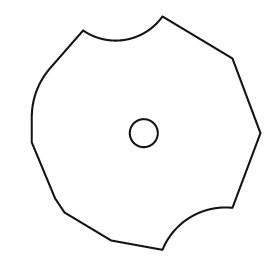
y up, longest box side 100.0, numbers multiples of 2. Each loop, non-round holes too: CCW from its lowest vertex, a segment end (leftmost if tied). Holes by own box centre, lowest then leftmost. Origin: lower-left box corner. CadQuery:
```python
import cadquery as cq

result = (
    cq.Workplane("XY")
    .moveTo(56.0, 0.0)
    .threePointArc((68.0, 14.0), (86.0, 18.0))
    .lineTo(98.0, 50.0)
    .lineTo(86.0, 82.0)
    .lineTo(56.0, 100.0)
    .threePointArc((40.0, 90.0), (22.0, 94.0))
    .lineTo(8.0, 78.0)
    .threePointArc((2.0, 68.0), (0.0, 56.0))
    .lineTo(0.0, 46.0)
    .lineTo(10.0, 22.0)
    .lineTo(14.0, 16.0)
    .lineTo(34.0, 4.0)
    .close()
    .moveTo(48.0, 50.0)
    .circle(6.0)
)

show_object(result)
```